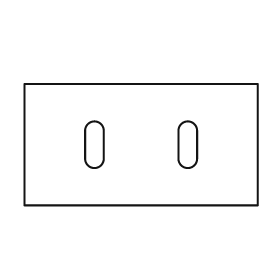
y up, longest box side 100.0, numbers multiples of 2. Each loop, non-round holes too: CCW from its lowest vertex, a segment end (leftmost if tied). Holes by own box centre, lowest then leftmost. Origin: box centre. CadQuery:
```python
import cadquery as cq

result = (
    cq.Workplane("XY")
    .moveTo(-50.0, -26.0)
    .lineTo(50.0, -26.0)
    .lineTo(50.0, 26.0)
    .lineTo(-50.0, 26.0)
    .close()
    .moveTo(-24.0, -6.0)
    .threePointArc((-20.0, -10.0), (-16.0, -6.0))
    .lineTo(-16.0, 6.0)
    .threePointArc((-20.0, 10.0), (-24.0, 6.0))
    .close()
    .moveTo(16.0, -6.0)
    .threePointArc((20.0, -10.0), (24.0, -6.0))
    .lineTo(24.0, 6.0)
    .threePointArc((20.0, 10.0), (16.0, 6.0))
    .close()
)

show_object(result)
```